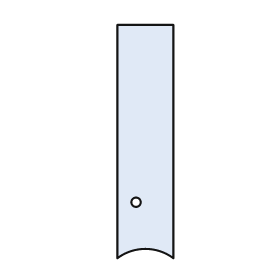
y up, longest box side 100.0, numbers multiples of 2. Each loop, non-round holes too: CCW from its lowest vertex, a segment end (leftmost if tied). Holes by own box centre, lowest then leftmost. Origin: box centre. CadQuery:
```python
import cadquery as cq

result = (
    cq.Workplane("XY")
    .moveTo(-12.0, -50.0)
    .threePointArc((0.0, -46.0), (12.0, -50.0))
    .lineTo(12.0, 50.0)
    .lineTo(-12.0, 50.0)
    .close()
    .moveTo(-4.0, -26.0)
    .circle(2.0)
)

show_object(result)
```